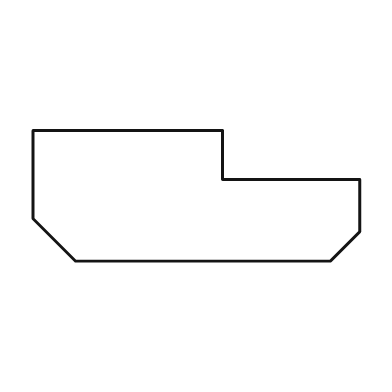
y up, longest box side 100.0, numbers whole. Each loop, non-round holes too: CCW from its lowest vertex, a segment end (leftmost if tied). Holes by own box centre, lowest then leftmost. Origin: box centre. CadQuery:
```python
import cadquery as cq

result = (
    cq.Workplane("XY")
    .moveTo(-37.0, -20.0)
    .lineTo(41.0, -20.0)
    .lineTo(50.0, -11.0)
    .lineTo(50.0, 5.0)
    .lineTo(8.0, 5.0)
    .lineTo(8.0, 20.0)
    .lineTo(-50.0, 20.0)
    .lineTo(-50.0, -7.0)
    .close()
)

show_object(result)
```